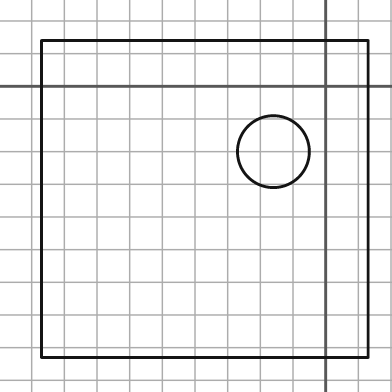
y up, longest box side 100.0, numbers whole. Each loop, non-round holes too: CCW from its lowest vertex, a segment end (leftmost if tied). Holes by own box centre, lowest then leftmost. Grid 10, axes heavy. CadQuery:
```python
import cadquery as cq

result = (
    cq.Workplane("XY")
    .moveTo(-87.0, -83.0)
    .lineTo(13.0, -83.0)
    .lineTo(13.0, 14.0)
    .lineTo(-87.0, 14.0)
    .close()
    .moveTo(-16.0, -20.0)
    .circle(11.0)
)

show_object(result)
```